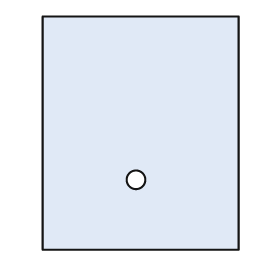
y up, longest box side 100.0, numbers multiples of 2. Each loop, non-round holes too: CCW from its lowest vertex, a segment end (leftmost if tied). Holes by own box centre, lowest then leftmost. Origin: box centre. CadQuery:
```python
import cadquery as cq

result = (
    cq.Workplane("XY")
    .moveTo(-42.0, -50.0)
    .lineTo(42.0, -50.0)
    .lineTo(42.0, 50.0)
    .lineTo(-42.0, 50.0)
    .close()
    .moveTo(-2.0, -20.0)
    .circle(4.0)
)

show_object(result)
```